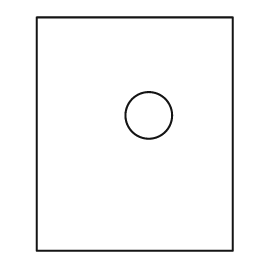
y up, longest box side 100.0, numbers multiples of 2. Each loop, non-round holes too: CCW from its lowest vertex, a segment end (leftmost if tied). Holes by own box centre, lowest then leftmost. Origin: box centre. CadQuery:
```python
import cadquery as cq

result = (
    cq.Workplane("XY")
    .moveTo(-42.0, -50.0)
    .lineTo(42.0, -50.0)
    .lineTo(42.0, 50.0)
    .lineTo(-42.0, 50.0)
    .close()
    .moveTo(6.0, 8.0)
    .circle(10.0)
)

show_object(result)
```